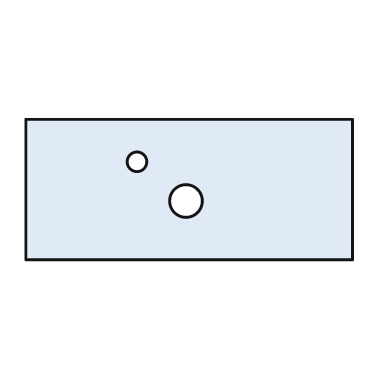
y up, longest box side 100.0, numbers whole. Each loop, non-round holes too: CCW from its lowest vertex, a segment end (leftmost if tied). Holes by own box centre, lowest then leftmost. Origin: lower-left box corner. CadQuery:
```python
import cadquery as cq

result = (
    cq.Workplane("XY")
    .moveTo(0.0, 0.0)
    .lineTo(100.0, 0.0)
    .lineTo(100.0, 43.0)
    .lineTo(0.0, 43.0)
    .close()
    .moveTo(49.0, 18.0)
    .circle(5.0)
    .moveTo(34.0, 30.0)
    .circle(3.0)
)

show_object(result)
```